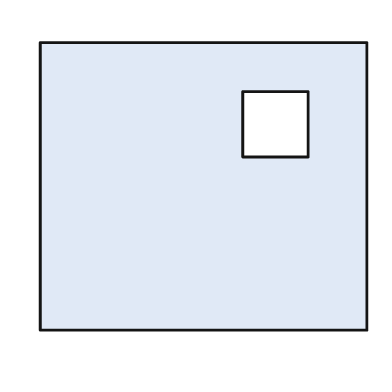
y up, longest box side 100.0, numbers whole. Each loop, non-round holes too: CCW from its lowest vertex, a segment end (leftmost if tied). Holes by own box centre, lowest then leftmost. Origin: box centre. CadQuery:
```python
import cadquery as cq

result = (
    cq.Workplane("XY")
    .moveTo(-50.0, -44.0)
    .lineTo(50.0, -44.0)
    .lineTo(50.0, 44.0)
    .lineTo(-50.0, 44.0)
    .close()
    .moveTo(12.0, 9.0)
    .lineTo(32.0, 9.0)
    .lineTo(32.0, 29.0)
    .lineTo(12.0, 29.0)
    .close()
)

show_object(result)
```